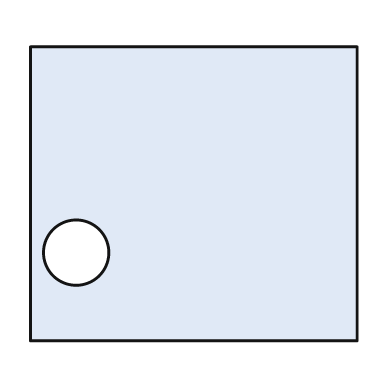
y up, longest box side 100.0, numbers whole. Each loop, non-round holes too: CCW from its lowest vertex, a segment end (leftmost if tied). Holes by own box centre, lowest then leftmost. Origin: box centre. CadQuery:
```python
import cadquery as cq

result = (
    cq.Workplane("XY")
    .moveTo(-50.0, -45.0)
    .lineTo(50.0, -45.0)
    .lineTo(50.0, 45.0)
    .lineTo(-50.0, 45.0)
    .close()
    .moveTo(-36.0, -18.0)
    .circle(10.0)
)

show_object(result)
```